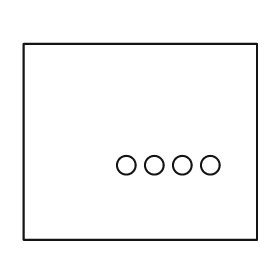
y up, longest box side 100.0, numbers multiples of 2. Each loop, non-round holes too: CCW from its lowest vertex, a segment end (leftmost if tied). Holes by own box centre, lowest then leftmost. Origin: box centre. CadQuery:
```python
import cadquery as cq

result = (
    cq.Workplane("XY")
    .moveTo(-50.0, -42.0)
    .lineTo(50.0, -42.0)
    .lineTo(50.0, 42.0)
    .lineTo(-50.0, 42.0)
    .close()
    .moveTo(-6.0, -10.0)
    .circle(4.0)
    .moveTo(6.0, -10.0)
    .circle(4.0)
    .moveTo(18.0, -10.0)
    .circle(4.0)
    .moveTo(30.0, -10.0)
    .circle(4.0)
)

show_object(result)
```